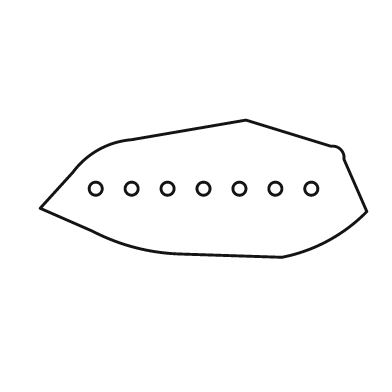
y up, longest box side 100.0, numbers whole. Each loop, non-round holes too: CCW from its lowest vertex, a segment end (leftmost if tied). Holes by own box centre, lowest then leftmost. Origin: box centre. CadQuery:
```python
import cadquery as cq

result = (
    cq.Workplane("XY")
    .moveTo(24.0, -21.0)
    .threePointArc((38.0, -16.0), (50.0, -7.0))
    .lineTo(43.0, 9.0)
    .threePointArc((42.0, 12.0), (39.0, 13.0))
    .lineTo(13.0, 21.0)
    .lineTo(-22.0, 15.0)
    .threePointArc((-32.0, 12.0), (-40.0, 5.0))
    .lineTo(-50.0, -6.0)
    .lineTo(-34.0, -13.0)
    .threePointArc((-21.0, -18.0), (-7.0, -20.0))
    .close()
    .moveTo(-33.0, 0.0)
    .circle(2.0)
    .moveTo(-22.0, 0.0)
    .circle(2.0)
    .moveTo(-11.0, 0.0)
    .circle(2.0)
    .moveTo(0.0, 0.0)
    .circle(2.0)
    .moveTo(11.0, 0.0)
    .circle(2.0)
    .moveTo(22.0, 0.0)
    .circle(2.0)
    .moveTo(33.0, 0.0)
    .circle(2.0)
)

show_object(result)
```